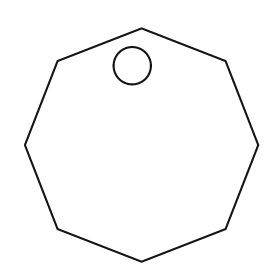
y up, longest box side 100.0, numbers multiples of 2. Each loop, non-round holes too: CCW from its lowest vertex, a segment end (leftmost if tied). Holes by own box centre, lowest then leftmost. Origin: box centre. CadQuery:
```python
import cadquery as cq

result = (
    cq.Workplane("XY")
    .moveTo(0.0, -50.0)
    .lineTo(36.0, -36.0)
    .lineTo(50.0, 0.0)
    .lineTo(36.0, 36.0)
    .lineTo(0.0, 50.0)
    .lineTo(-36.0, 36.0)
    .lineTo(-50.0, 0.0)
    .lineTo(-36.0, -36.0)
    .close()
    .moveTo(-4.0, 34.0)
    .circle(8.0)
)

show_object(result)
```